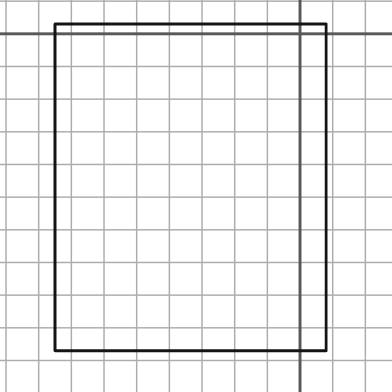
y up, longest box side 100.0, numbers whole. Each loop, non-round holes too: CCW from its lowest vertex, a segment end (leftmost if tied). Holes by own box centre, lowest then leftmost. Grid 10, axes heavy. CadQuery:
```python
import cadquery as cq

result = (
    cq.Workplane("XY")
    .moveTo(-75.0, -97.0)
    .lineTo(8.0, -97.0)
    .lineTo(8.0, 3.0)
    .lineTo(-75.0, 3.0)
    .close()
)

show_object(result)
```